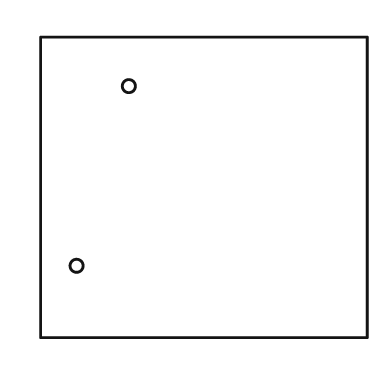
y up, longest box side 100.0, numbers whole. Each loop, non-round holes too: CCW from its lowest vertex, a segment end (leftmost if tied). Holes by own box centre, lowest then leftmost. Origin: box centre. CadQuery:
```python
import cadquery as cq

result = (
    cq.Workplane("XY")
    .moveTo(-50.0, -46.0)
    .lineTo(50.0, -46.0)
    .lineTo(50.0, 46.0)
    .lineTo(-50.0, 46.0)
    .close()
    .moveTo(-39.0, -24.0)
    .circle(2.0)
    .moveTo(-23.0, 31.0)
    .circle(2.0)
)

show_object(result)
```